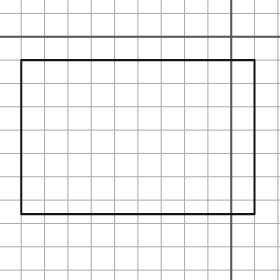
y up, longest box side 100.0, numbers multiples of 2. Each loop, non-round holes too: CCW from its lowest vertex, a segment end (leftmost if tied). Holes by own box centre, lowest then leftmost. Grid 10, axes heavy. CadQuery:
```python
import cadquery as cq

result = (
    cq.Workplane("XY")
    .moveTo(-90.0, -76.0)
    .lineTo(10.0, -76.0)
    .lineTo(10.0, -10.0)
    .lineTo(-90.0, -10.0)
    .close()
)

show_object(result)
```